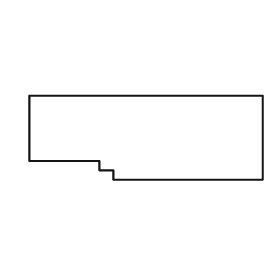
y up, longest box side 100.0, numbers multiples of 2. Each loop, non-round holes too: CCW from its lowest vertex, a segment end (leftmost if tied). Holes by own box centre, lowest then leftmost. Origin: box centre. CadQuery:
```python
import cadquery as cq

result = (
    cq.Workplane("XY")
    .moveTo(-14.0, -18.0)
    .lineTo(50.0, -18.0)
    .lineTo(50.0, 18.0)
    .lineTo(-50.0, 18.0)
    .lineTo(-50.0, -10.0)
    .lineTo(-20.0, -10.0)
    .lineTo(-20.0, -14.0)
    .lineTo(-14.0, -14.0)
    .close()
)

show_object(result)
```